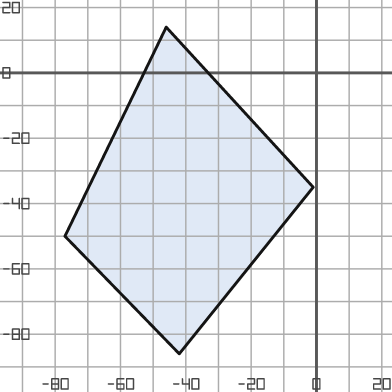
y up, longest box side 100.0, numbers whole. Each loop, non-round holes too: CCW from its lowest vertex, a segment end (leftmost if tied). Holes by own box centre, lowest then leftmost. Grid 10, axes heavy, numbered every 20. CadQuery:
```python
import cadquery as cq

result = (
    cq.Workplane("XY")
    .moveTo(-42.0, -86.0)
    .lineTo(-1.0, -35.0)
    .lineTo(-46.0, 14.0)
    .lineTo(-77.0, -50.0)
    .close()
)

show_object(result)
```